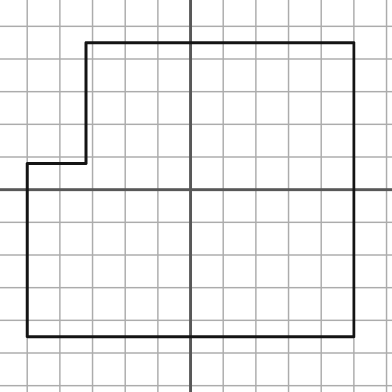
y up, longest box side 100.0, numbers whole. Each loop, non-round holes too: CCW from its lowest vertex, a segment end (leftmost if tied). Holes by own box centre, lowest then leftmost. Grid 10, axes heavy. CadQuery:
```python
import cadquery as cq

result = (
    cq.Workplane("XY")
    .moveTo(-50.0, -45.0)
    .lineTo(50.0, -45.0)
    .lineTo(50.0, 45.0)
    .lineTo(-32.0, 45.0)
    .lineTo(-32.0, 8.0)
    .lineTo(-50.0, 8.0)
    .close()
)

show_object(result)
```